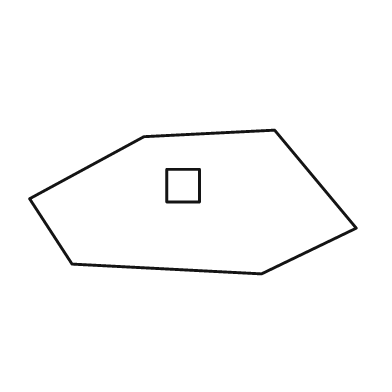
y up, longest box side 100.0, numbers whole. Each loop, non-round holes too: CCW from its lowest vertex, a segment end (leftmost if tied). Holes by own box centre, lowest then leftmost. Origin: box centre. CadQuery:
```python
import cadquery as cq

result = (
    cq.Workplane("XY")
    .moveTo(21.0, -22.0)
    .lineTo(50.0, -8.0)
    .lineTo(25.0, 22.0)
    .lineTo(-15.0, 20.0)
    .lineTo(-50.0, 1.0)
    .lineTo(-37.0, -19.0)
    .close()
    .moveTo(-8.0, 0.0)
    .lineTo(2.0, 0.0)
    .lineTo(2.0, 10.0)
    .lineTo(-8.0, 10.0)
    .close()
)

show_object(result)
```